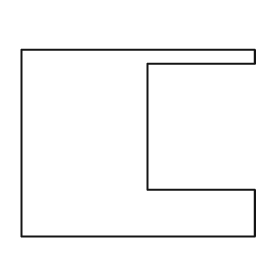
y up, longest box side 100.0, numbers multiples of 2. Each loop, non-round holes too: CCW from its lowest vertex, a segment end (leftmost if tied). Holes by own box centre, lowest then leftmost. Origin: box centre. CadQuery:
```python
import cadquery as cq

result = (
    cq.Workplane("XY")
    .moveTo(-50.0, -40.0)
    .lineTo(50.0, -40.0)
    .lineTo(50.0, -20.0)
    .lineTo(4.0, -20.0)
    .lineTo(4.0, 34.0)
    .lineTo(50.0, 34.0)
    .lineTo(50.0, 40.0)
    .lineTo(-50.0, 40.0)
    .close()
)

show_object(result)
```